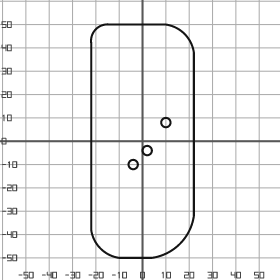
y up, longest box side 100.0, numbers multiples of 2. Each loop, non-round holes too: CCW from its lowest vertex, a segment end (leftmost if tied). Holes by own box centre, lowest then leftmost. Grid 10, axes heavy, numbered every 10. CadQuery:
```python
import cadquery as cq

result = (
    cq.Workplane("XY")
    .moveTo(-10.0, -50.0)
    .lineTo(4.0, -50.0)
    .threePointArc((16.0, -44.0), (22.0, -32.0))
    .lineTo(22.0, 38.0)
    .threePointArc((18.0, 46.0), (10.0, 50.0))
    .lineTo(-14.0, 50.0)
    .threePointArc((-20.0, 48.0), (-22.0, 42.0))
    .lineTo(-22.0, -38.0)
    .threePointArc((-18.0, -46.0), (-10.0, -50.0))
    .close()
    .moveTo(-4.0, -10.0)
    .circle(2.0)
    .moveTo(2.0, -4.0)
    .circle(2.0)
    .moveTo(10.0, 8.0)
    .circle(2.0)
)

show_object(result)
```